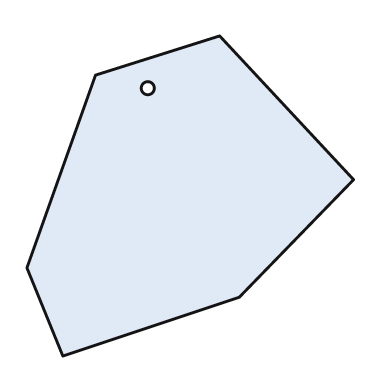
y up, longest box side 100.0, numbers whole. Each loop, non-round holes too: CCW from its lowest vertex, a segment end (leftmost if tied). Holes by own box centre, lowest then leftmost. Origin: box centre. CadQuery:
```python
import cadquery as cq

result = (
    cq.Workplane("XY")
    .moveTo(-39.0, -49.0)
    .lineTo(15.0, -31.0)
    .lineTo(50.0, 5.0)
    .lineTo(9.0, 49.0)
    .lineTo(-29.0, 37.0)
    .lineTo(-50.0, -22.0)
    .close()
    .moveTo(-13.0, 33.0)
    .circle(2.0)
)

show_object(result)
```